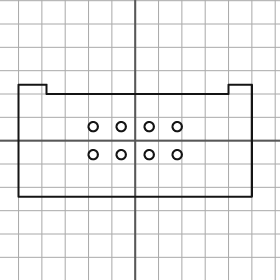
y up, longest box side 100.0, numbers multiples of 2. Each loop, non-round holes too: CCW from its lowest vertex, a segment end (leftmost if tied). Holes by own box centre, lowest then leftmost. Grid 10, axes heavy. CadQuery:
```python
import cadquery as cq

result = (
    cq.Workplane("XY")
    .moveTo(-50.0, -24.0)
    .lineTo(50.0, -24.0)
    .lineTo(50.0, 24.0)
    .lineTo(40.0, 24.0)
    .lineTo(40.0, 20.0)
    .lineTo(-38.0, 20.0)
    .lineTo(-38.0, 24.0)
    .lineTo(-50.0, 24.0)
    .close()
    .moveTo(-18.0, -6.0)
    .circle(2.0)
    .moveTo(-6.0, -6.0)
    .circle(2.0)
    .moveTo(6.0, -6.0)
    .circle(2.0)
    .moveTo(18.0, -6.0)
    .circle(2.0)
    .moveTo(-18.0, 6.0)
    .circle(2.0)
    .moveTo(-6.0, 6.0)
    .circle(2.0)
    .moveTo(6.0, 6.0)
    .circle(2.0)
    .moveTo(18.0, 6.0)
    .circle(2.0)
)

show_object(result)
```